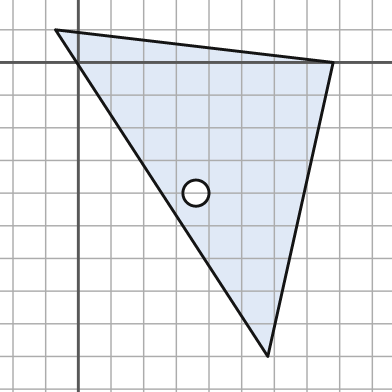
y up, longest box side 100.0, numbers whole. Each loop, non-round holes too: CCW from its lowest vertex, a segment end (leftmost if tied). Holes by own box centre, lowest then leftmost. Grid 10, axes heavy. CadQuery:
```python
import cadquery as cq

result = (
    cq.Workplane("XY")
    .moveTo(58.0, -90.0)
    .lineTo(78.0, 0.0)
    .lineTo(-7.0, 10.0)
    .close()
    .moveTo(36.0, -40.0)
    .circle(4.0)
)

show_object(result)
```